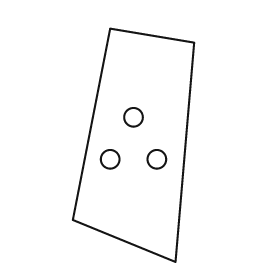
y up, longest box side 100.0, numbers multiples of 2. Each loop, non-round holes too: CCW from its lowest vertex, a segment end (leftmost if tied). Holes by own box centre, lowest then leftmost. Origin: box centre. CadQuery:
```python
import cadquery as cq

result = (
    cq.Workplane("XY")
    .moveTo(18.0, -50.0)
    .lineTo(26.0, 44.0)
    .lineTo(-10.0, 50.0)
    .lineTo(-26.0, -32.0)
    .close()
    .moveTo(-10.0, -6.0)
    .circle(4.0)
    .moveTo(10.0, -6.0)
    .circle(4.0)
    .moveTo(0.0, 12.0)
    .circle(4.0)
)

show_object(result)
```